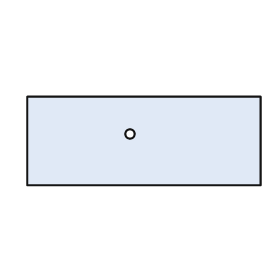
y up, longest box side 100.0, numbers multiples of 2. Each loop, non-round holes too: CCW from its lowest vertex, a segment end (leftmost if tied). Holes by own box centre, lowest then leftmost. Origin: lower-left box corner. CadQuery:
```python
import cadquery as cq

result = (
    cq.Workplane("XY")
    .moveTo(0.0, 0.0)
    .lineTo(100.0, 0.0)
    .lineTo(100.0, 38.0)
    .lineTo(0.0, 38.0)
    .close()
    .moveTo(44.0, 22.0)
    .circle(2.0)
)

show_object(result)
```